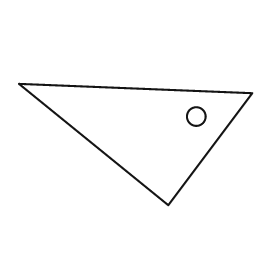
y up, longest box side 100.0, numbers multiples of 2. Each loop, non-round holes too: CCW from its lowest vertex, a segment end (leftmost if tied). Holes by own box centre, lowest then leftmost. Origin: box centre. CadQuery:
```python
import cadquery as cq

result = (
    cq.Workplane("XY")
    .moveTo(14.0, -26.0)
    .lineTo(50.0, 22.0)
    .lineTo(-50.0, 26.0)
    .close()
    .moveTo(26.0, 12.0)
    .circle(4.0)
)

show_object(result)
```